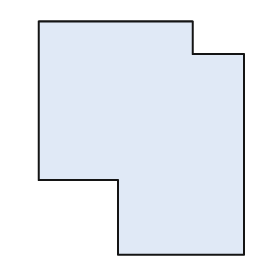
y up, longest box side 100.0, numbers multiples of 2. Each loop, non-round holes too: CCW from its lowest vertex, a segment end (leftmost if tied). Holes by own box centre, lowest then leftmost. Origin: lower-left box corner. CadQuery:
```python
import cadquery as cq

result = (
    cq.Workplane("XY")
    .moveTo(34.0, 0.0)
    .lineTo(88.0, 0.0)
    .lineTo(88.0, 86.0)
    .lineTo(66.0, 86.0)
    .lineTo(66.0, 100.0)
    .lineTo(0.0, 100.0)
    .lineTo(0.0, 32.0)
    .lineTo(34.0, 32.0)
    .close()
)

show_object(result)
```